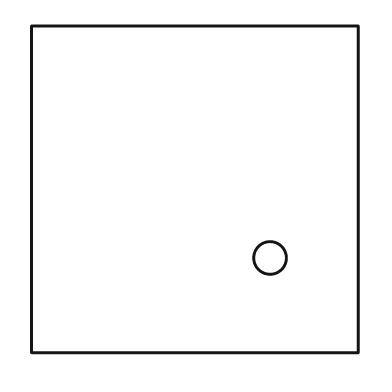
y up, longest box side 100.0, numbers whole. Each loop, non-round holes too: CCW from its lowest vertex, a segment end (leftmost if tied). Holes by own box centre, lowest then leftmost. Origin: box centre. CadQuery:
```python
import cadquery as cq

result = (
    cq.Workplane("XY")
    .moveTo(-50.0, -50.0)
    .lineTo(50.0, -50.0)
    .lineTo(50.0, 50.0)
    .lineTo(-50.0, 50.0)
    .close()
    .moveTo(23.0, -21.0)
    .circle(5.0)
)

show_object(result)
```